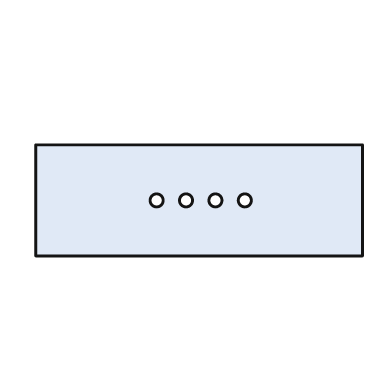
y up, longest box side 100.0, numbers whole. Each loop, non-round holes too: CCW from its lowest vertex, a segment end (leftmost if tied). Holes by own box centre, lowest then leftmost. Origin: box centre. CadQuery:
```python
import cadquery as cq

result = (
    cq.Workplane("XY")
    .moveTo(-50.0, -17.0)
    .lineTo(50.0, -17.0)
    .lineTo(50.0, 17.0)
    .lineTo(-50.0, 17.0)
    .close()
    .moveTo(-13.0, 0.0)
    .circle(2.0)
    .moveTo(-4.0, 0.0)
    .circle(2.0)
    .moveTo(5.0, 0.0)
    .circle(2.0)
    .moveTo(14.0, 0.0)
    .circle(2.0)
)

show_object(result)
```